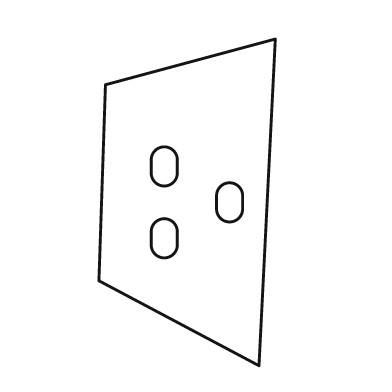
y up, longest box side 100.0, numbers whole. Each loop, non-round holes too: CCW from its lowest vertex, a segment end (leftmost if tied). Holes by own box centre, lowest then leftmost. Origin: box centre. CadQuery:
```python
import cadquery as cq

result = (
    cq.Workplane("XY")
    .moveTo(22.0, -50.0)
    .lineTo(27.0, 50.0)
    .lineTo(-25.0, 36.0)
    .lineTo(-27.0, -24.0)
    .close()
    .moveTo(-11.0, -13.0)
    .threePointArc((-7.0, -17.0), (-3.0, -13.0))
    .lineTo(-3.0, -9.0)
    .threePointArc((-7.0, -5.0), (-11.0, -9.0))
    .close()
    .moveTo(9.0, -2.0)
    .threePointArc((13.0, -6.0), (17.0, -2.0))
    .lineTo(17.0, 2.0)
    .threePointArc((13.0, 6.0), (9.0, 2.0))
    .close()
    .moveTo(-11.0, 9.0)
    .threePointArc((-7.0, 5.0), (-3.0, 9.0))
    .lineTo(-3.0, 13.0)
    .threePointArc((-7.0, 17.0), (-11.0, 13.0))
    .close()
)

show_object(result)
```